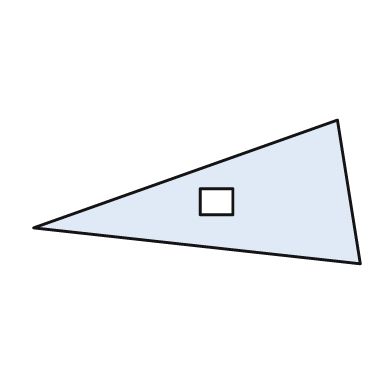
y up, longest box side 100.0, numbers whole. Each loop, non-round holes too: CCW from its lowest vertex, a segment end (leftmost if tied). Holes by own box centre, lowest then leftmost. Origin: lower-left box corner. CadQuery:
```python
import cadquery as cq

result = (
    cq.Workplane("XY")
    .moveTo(100.0, 0.0)
    .lineTo(93.0, 44.0)
    .lineTo(0.0, 11.0)
    .close()
    .moveTo(51.0, 15.0)
    .lineTo(61.0, 15.0)
    .lineTo(61.0, 23.0)
    .lineTo(51.0, 23.0)
    .close()
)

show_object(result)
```